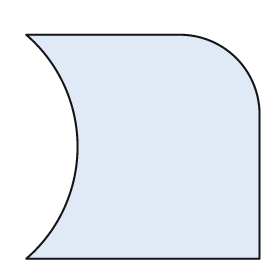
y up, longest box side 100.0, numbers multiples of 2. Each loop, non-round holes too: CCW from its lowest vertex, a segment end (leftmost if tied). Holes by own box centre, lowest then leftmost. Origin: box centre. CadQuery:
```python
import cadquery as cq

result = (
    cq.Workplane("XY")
    .moveTo(-50.0, -48.0)
    .lineTo(50.0, -48.0)
    .lineTo(50.0, 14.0)
    .threePointArc((40.0, 38.0), (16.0, 48.0))
    .lineTo(-50.0, 48.0)
    .threePointArc((-28.0, 0.0), (-50.0, -48.0))
    .close()
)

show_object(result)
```